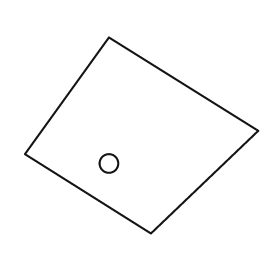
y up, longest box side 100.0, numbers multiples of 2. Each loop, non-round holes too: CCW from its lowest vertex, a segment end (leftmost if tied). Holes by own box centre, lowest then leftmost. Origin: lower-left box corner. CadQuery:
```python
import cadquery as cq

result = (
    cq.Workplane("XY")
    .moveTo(54.0, 0.0)
    .lineTo(100.0, 44.0)
    .lineTo(36.0, 84.0)
    .lineTo(0.0, 34.0)
    .close()
    .moveTo(36.0, 30.0)
    .circle(4.0)
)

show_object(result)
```